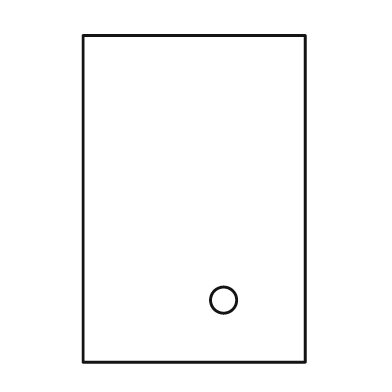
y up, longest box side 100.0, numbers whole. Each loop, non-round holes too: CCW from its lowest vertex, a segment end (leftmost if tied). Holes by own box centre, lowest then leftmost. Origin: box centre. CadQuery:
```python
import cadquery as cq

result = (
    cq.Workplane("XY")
    .moveTo(-34.0, -50.0)
    .lineTo(34.0, -50.0)
    .lineTo(34.0, 50.0)
    .lineTo(-34.0, 50.0)
    .close()
    .moveTo(9.0, -31.0)
    .circle(4.0)
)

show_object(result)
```